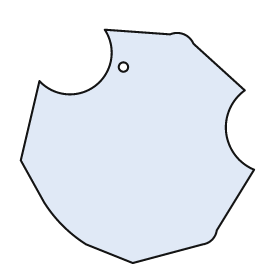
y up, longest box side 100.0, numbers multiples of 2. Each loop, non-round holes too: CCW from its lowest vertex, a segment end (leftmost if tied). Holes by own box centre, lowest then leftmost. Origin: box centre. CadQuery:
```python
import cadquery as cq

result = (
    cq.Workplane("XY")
    .moveTo(-2.0, -50.0)
    .lineTo(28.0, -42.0)
    .threePointArc((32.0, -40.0), (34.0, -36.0))
    .lineTo(50.0, -10.0)
    .threePointArc((38.0, 6.0), (46.0, 24.0))
    .lineTo(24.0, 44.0)
    .threePointArc((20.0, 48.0), (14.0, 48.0))
    .lineTo(-14.0, 50.0)
    .threePointArc((-18.0, 26.0), (-42.0, 28.0))
    .lineTo(-50.0, -6.0)
    .lineTo(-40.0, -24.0)
    .threePointArc((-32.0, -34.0), (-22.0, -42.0))
    .close()
    .moveTo(-6.0, 34.0)
    .circle(2.0)
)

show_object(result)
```